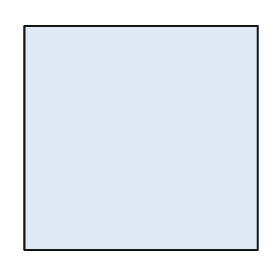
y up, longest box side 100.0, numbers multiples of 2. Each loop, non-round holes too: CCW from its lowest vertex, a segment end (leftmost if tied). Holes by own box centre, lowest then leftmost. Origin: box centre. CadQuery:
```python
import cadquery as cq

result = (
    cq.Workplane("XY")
    .moveTo(-50.0, -48.0)
    .lineTo(50.0, -48.0)
    .lineTo(50.0, 48.0)
    .lineTo(-50.0, 48.0)
    .close()
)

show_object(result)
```